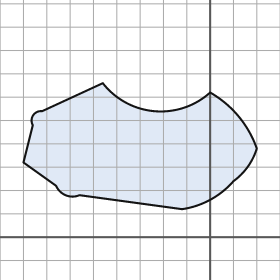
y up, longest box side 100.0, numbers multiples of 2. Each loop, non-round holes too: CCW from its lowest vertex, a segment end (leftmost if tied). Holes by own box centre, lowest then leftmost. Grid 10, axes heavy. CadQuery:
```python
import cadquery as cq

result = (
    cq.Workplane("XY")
    .moveTo(-12.0, 12.0)
    .threePointArc((0.0, 16.0), (10.0, 24.0))
    .threePointArc((16.0, 30.0), (20.0, 38.0))
    .threePointArc((12.0, 52.0), (0.0, 62.0))
    .threePointArc((-24.0, 54.0), (-46.0, 66.0))
    .lineTo(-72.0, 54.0)
    .threePointArc((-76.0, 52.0), (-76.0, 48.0))
    .lineTo(-80.0, 32.0)
    .lineTo(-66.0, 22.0)
    .threePointArc((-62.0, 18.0), (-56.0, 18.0))
    .close()
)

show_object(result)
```